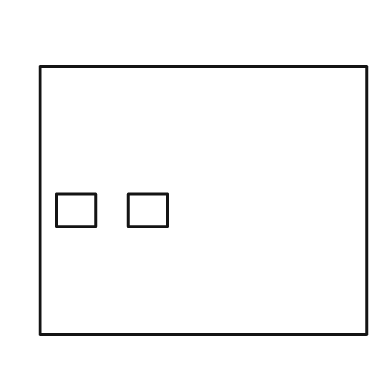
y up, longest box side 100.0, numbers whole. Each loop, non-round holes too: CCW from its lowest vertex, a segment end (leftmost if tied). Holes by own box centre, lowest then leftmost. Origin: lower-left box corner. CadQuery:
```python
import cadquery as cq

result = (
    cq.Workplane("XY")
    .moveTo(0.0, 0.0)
    .lineTo(100.0, 0.0)
    .lineTo(100.0, 82.0)
    .lineTo(0.0, 82.0)
    .close()
    .moveTo(5.0, 33.0)
    .lineTo(17.0, 33.0)
    .lineTo(17.0, 43.0)
    .lineTo(5.0, 43.0)
    .close()
    .moveTo(27.0, 33.0)
    .lineTo(39.0, 33.0)
    .lineTo(39.0, 43.0)
    .lineTo(27.0, 43.0)
    .close()
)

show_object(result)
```